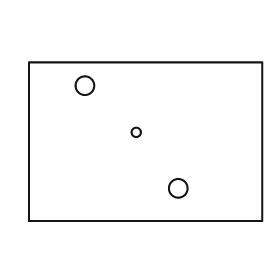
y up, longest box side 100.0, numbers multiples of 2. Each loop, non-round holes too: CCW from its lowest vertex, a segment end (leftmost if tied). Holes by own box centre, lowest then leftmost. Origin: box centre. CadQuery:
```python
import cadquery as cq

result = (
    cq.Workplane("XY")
    .moveTo(-50.0, -34.0)
    .lineTo(50.0, -34.0)
    .lineTo(50.0, 34.0)
    .lineTo(-50.0, 34.0)
    .close()
    .moveTo(14.0, -20.0)
    .circle(4.0)
    .moveTo(-4.0, 4.0)
    .circle(2.0)
    .moveTo(-26.0, 24.0)
    .circle(4.0)
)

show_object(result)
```